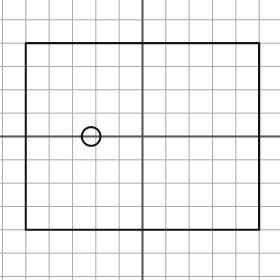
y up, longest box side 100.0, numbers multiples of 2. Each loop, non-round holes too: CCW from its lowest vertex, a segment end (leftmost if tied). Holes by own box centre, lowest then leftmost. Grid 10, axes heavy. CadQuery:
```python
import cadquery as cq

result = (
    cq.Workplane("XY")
    .moveTo(-50.0, -40.0)
    .lineTo(50.0, -40.0)
    .lineTo(50.0, 40.0)
    .lineTo(-50.0, 40.0)
    .close()
    .moveTo(-22.0, 0.0)
    .circle(4.0)
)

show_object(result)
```